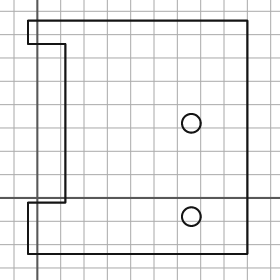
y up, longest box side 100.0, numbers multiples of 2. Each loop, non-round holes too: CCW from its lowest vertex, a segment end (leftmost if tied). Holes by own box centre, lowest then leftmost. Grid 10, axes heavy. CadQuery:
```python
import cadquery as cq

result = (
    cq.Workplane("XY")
    .moveTo(-4.0, -24.0)
    .lineTo(90.0, -24.0)
    .lineTo(90.0, 76.0)
    .lineTo(-4.0, 76.0)
    .lineTo(-4.0, 66.0)
    .lineTo(12.0, 66.0)
    .lineTo(12.0, -2.0)
    .lineTo(-4.0, -2.0)
    .close()
    .moveTo(66.0, -8.0)
    .circle(4.0)
    .moveTo(66.0, 32.0)
    .circle(4.0)
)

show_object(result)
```